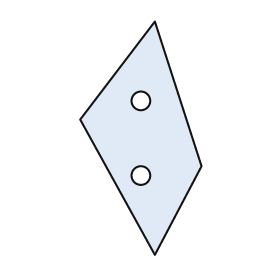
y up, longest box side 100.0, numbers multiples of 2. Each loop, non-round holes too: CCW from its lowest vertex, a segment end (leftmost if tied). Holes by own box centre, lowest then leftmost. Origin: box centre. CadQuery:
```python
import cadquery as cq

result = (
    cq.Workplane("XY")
    .moveTo(6.0, -50.0)
    .lineTo(26.0, -12.0)
    .lineTo(6.0, 50.0)
    .lineTo(-26.0, 8.0)
    .close()
    .moveTo(0.0, -16.0)
    .circle(4.0)
    .moveTo(0.0, 16.0)
    .circle(4.0)
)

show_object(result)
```